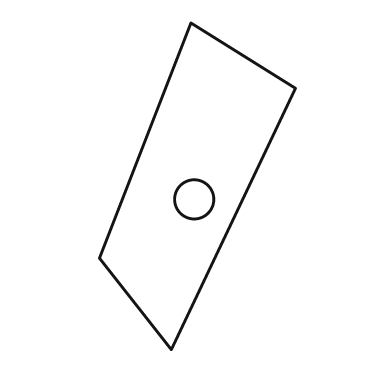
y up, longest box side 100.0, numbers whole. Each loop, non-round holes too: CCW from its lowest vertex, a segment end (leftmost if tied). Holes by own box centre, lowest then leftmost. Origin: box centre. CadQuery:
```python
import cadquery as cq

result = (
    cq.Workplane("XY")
    .moveTo(-8.0, -50.0)
    .lineTo(30.0, 30.0)
    .lineTo(-2.0, 50.0)
    .lineTo(-30.0, -22.0)
    .close()
    .moveTo(-1.0, -4.0)
    .circle(6.0)
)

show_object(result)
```